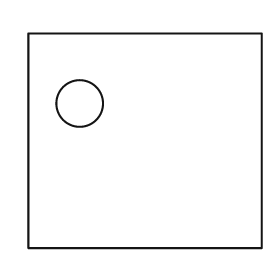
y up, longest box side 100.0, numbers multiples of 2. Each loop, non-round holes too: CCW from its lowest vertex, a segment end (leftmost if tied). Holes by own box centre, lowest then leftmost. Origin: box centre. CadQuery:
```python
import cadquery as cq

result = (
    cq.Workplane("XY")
    .moveTo(-50.0, -46.0)
    .lineTo(50.0, -46.0)
    .lineTo(50.0, 46.0)
    .lineTo(-50.0, 46.0)
    .close()
    .moveTo(-28.0, 16.0)
    .circle(10.0)
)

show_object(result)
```